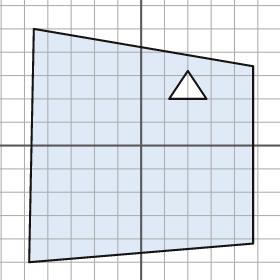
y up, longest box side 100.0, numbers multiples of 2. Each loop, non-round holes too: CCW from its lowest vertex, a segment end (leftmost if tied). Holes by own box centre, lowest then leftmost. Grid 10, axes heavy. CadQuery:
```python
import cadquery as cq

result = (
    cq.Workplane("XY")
    .moveTo(-48.0, -50.0)
    .lineTo(48.0, -42.0)
    .lineTo(48.0, 34.0)
    .lineTo(-46.0, 50.0)
    .close()
    .moveTo(12.0, 20.0)
    .lineTo(28.0, 20.0)
    .lineTo(20.0, 32.0)
    .close()
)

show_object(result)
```